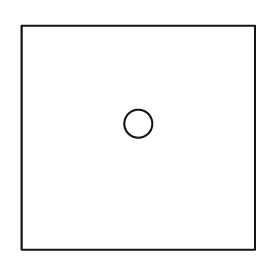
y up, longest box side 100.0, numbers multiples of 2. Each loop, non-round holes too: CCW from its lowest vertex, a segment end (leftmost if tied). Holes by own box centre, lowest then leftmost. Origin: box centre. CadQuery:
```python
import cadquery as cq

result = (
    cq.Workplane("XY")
    .moveTo(-50.0, -48.0)
    .lineTo(50.0, -48.0)
    .lineTo(50.0, 48.0)
    .lineTo(-50.0, 48.0)
    .close()
    .moveTo(0.0, 6.0)
    .circle(6.0)
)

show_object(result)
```